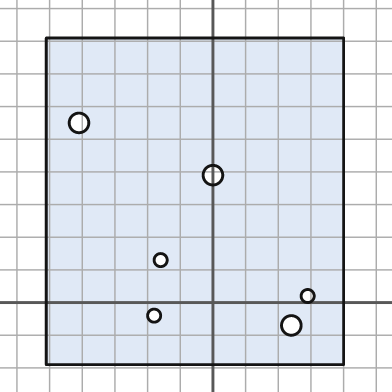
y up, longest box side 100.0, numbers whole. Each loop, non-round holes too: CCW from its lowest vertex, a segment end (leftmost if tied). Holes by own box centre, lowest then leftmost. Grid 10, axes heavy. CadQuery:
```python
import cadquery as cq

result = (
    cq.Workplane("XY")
    .moveTo(-51.0, -19.0)
    .lineTo(40.0, -19.0)
    .lineTo(40.0, 81.0)
    .lineTo(-51.0, 81.0)
    .close()
    .moveTo(24.0, -7.0)
    .circle(3.0)
    .moveTo(-18.0, -4.0)
    .circle(2.0)
    .moveTo(29.0, 2.0)
    .circle(2.0)
    .moveTo(-16.0, 13.0)
    .circle(2.0)
    .moveTo(0.0, 39.0)
    .circle(3.0)
    .moveTo(-41.0, 55.0)
    .circle(3.0)
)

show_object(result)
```